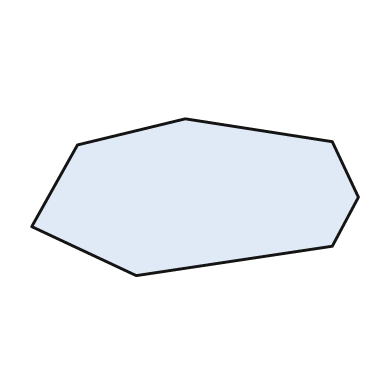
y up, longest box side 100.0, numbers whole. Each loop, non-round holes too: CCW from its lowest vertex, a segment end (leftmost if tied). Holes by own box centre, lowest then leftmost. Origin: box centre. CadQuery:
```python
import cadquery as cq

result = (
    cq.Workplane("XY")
    .moveTo(-18.0, -24.0)
    .lineTo(42.0, -15.0)
    .lineTo(50.0, 0.0)
    .lineTo(42.0, 17.0)
    .lineTo(-3.0, 24.0)
    .lineTo(-36.0, 16.0)
    .lineTo(-50.0, -9.0)
    .close()
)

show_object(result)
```